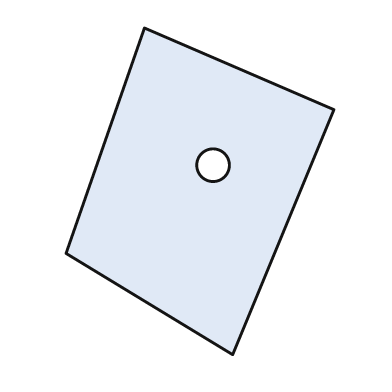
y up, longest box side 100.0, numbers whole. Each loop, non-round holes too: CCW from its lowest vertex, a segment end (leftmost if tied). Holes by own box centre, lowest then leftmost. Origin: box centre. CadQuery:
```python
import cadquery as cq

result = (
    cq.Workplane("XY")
    .moveTo(10.0, -50.0)
    .lineTo(41.0, 25.0)
    .lineTo(-17.0, 50.0)
    .lineTo(-41.0, -19.0)
    .close()
    .moveTo(4.0, 8.0)
    .circle(5.0)
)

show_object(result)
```